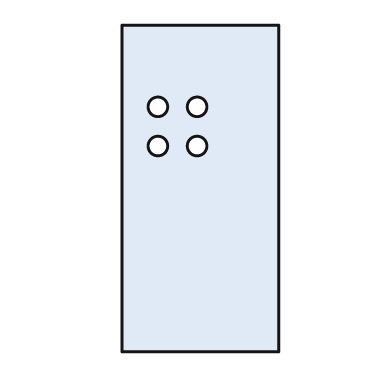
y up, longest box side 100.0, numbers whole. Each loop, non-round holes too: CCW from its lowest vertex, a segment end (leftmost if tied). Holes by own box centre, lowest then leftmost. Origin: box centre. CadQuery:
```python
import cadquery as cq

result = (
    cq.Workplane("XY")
    .moveTo(-24.0, -50.0)
    .lineTo(24.0, -50.0)
    .lineTo(24.0, 50.0)
    .lineTo(-24.0, 50.0)
    .close()
    .moveTo(-13.0, 13.0)
    .circle(3.0)
    .moveTo(-1.0, 13.0)
    .circle(3.0)
    .moveTo(-13.0, 25.0)
    .circle(3.0)
    .moveTo(-1.0, 25.0)
    .circle(3.0)
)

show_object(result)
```